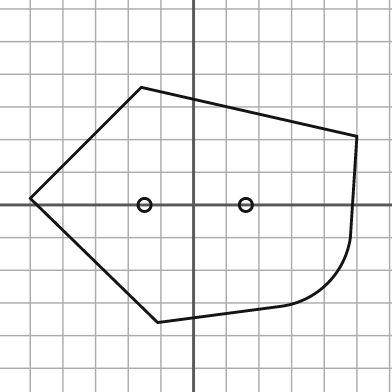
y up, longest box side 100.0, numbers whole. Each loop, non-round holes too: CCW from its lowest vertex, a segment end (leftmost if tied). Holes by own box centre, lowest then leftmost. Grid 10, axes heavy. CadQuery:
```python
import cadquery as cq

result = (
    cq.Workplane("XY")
    .moveTo(-11.0, -36.0)
    .lineTo(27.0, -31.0)
    .threePointArc((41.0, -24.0), (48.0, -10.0))
    .lineTo(50.0, 21.0)
    .lineTo(-16.0, 36.0)
    .lineTo(-50.0, 2.0)
    .close()
    .moveTo(-15.0, 0.0)
    .circle(2.0)
    .moveTo(16.0, 0.0)
    .circle(2.0)
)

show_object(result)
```